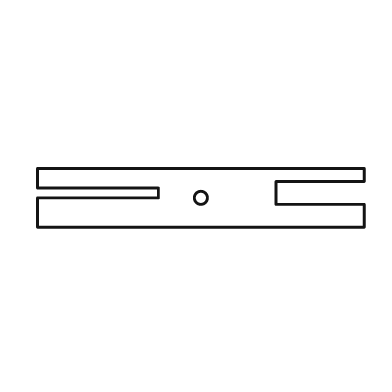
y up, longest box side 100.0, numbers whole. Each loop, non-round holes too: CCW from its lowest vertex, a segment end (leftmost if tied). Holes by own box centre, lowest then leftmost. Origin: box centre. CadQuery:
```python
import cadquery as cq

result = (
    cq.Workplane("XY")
    .moveTo(-50.0, -9.0)
    .lineTo(50.0, -9.0)
    .lineTo(50.0, -2.0)
    .lineTo(23.0, -2.0)
    .lineTo(23.0, 5.0)
    .lineTo(50.0, 5.0)
    .lineTo(50.0, 9.0)
    .lineTo(-50.0, 9.0)
    .lineTo(-50.0, 3.0)
    .lineTo(-13.0, 3.0)
    .lineTo(-13.0, 0.0)
    .lineTo(-50.0, 0.0)
    .close()
    .moveTo(0.0, 0.0)
    .circle(2.0)
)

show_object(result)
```